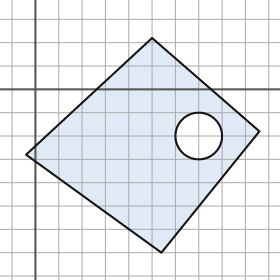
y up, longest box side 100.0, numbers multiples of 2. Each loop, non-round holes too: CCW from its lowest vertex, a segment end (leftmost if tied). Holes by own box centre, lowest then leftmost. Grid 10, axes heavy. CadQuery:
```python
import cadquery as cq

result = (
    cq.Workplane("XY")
    .moveTo(54.0, -70.0)
    .lineTo(96.0, -18.0)
    .lineTo(50.0, 22.0)
    .lineTo(-4.0, -28.0)
    .close()
    .moveTo(70.0, -20.0)
    .circle(10.0)
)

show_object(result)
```